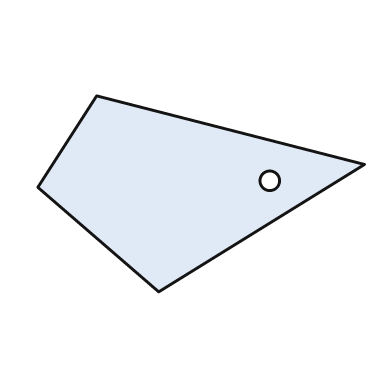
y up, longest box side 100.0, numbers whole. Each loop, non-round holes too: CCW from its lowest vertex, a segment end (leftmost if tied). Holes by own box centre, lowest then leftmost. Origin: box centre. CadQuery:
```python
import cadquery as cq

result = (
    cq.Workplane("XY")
    .moveTo(-13.0, -30.0)
    .lineTo(50.0, 9.0)
    .lineTo(-32.0, 30.0)
    .lineTo(-50.0, 2.0)
    .close()
    .moveTo(21.0, 4.0)
    .circle(3.0)
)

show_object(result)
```